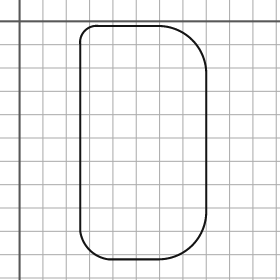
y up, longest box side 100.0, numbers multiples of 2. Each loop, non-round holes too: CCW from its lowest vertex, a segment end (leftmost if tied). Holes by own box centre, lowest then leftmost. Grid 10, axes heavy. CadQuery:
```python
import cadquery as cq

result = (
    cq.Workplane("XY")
    .moveTo(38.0, -102.0)
    .lineTo(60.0, -102.0)
    .threePointArc((74.0, -96.0), (80.0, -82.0))
    .lineTo(80.0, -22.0)
    .threePointArc((74.0, -8.0), (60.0, -2.0))
    .lineTo(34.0, -2.0)
    .threePointArc((28.0, -4.0), (26.0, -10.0))
    .lineTo(26.0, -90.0)
    .threePointArc((30.0, -98.0), (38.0, -102.0))
    .close()
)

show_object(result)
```